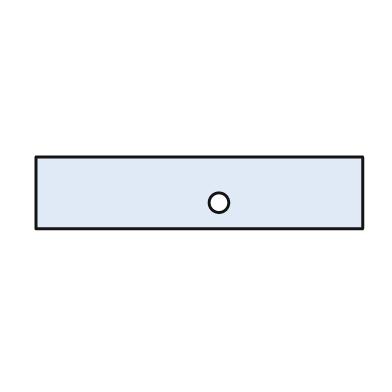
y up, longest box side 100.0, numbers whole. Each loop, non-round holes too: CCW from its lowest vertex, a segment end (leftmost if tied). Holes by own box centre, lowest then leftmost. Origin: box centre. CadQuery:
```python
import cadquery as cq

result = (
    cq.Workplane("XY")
    .moveTo(-50.0, -11.0)
    .lineTo(50.0, -11.0)
    .lineTo(50.0, 11.0)
    .lineTo(-50.0, 11.0)
    .close()
    .moveTo(6.0, -3.0)
    .circle(3.0)
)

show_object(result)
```